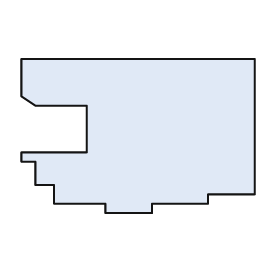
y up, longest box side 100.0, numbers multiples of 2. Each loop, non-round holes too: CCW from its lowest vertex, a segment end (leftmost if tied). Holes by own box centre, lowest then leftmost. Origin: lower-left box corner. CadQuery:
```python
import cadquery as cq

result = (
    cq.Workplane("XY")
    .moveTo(36.0, 0.0)
    .lineTo(56.0, 0.0)
    .lineTo(56.0, 4.0)
    .lineTo(80.0, 4.0)
    .lineTo(80.0, 8.0)
    .lineTo(100.0, 8.0)
    .lineTo(100.0, 66.0)
    .lineTo(0.0, 66.0)
    .lineTo(0.0, 50.0)
    .lineTo(6.0, 46.0)
    .lineTo(28.0, 46.0)
    .lineTo(28.0, 26.0)
    .lineTo(0.0, 26.0)
    .lineTo(0.0, 22.0)
    .lineTo(6.0, 22.0)
    .lineTo(6.0, 12.0)
    .lineTo(14.0, 12.0)
    .lineTo(14.0, 4.0)
    .lineTo(36.0, 4.0)
    .close()
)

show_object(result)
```